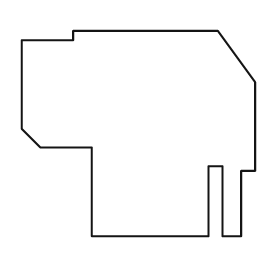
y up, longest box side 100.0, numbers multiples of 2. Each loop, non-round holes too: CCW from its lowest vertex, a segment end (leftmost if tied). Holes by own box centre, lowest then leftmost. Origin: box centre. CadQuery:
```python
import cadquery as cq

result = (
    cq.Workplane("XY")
    .moveTo(-20.0, -44.0)
    .lineTo(30.0, -44.0)
    .lineTo(30.0, -14.0)
    .lineTo(36.0, -14.0)
    .lineTo(36.0, -44.0)
    .lineTo(44.0, -44.0)
    .lineTo(44.0, -16.0)
    .lineTo(50.0, -16.0)
    .lineTo(50.0, 22.0)
    .lineTo(34.0, 44.0)
    .lineTo(-28.0, 44.0)
    .lineTo(-28.0, 40.0)
    .lineTo(-50.0, 40.0)
    .lineTo(-50.0, 2.0)
    .lineTo(-42.0, -6.0)
    .lineTo(-20.0, -6.0)
    .close()
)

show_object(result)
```